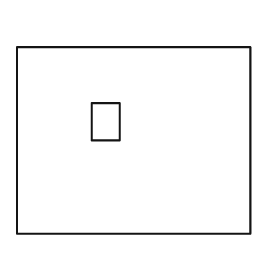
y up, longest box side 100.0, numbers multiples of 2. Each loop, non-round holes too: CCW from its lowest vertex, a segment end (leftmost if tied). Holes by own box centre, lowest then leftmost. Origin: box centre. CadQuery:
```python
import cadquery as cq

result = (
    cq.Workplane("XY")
    .moveTo(-50.0, -40.0)
    .lineTo(50.0, -40.0)
    .lineTo(50.0, 40.0)
    .lineTo(-50.0, 40.0)
    .close()
    .moveTo(-18.0, 0.0)
    .lineTo(-6.0, 0.0)
    .lineTo(-6.0, 16.0)
    .lineTo(-18.0, 16.0)
    .close()
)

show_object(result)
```